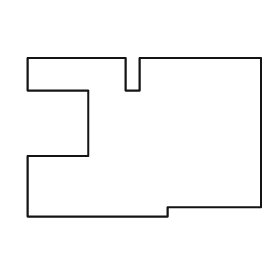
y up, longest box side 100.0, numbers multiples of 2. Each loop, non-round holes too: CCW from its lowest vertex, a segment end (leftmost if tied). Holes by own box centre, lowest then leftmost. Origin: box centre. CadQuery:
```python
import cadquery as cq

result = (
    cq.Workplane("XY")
    .moveTo(-50.0, -34.0)
    .lineTo(10.0, -34.0)
    .lineTo(10.0, -30.0)
    .lineTo(50.0, -30.0)
    .lineTo(50.0, 34.0)
    .lineTo(-2.0, 34.0)
    .lineTo(-2.0, 20.0)
    .lineTo(-8.0, 20.0)
    .lineTo(-8.0, 34.0)
    .lineTo(-50.0, 34.0)
    .lineTo(-50.0, 20.0)
    .lineTo(-24.0, 20.0)
    .lineTo(-24.0, -8.0)
    .lineTo(-50.0, -8.0)
    .close()
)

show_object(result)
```